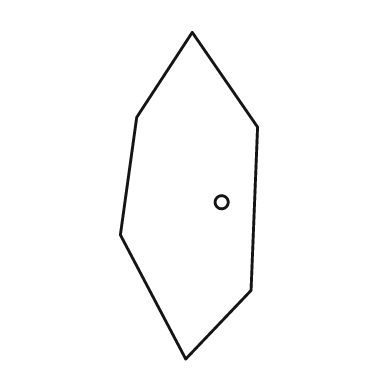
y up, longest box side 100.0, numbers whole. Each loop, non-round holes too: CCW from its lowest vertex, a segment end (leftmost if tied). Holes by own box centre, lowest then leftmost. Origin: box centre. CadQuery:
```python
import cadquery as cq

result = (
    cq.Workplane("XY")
    .moveTo(-1.0, -50.0)
    .lineTo(19.0, -29.0)
    .lineTo(21.0, 21.0)
    .lineTo(1.0, 50.0)
    .lineTo(-16.0, 24.0)
    .lineTo(-21.0, -12.0)
    .close()
    .moveTo(10.0, -2.0)
    .circle(2.0)
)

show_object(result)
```